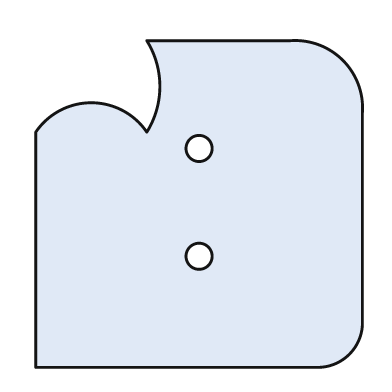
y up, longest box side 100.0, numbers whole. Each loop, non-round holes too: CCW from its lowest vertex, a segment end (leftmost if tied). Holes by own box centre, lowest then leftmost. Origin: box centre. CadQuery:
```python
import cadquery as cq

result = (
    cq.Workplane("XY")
    .moveTo(-50.0, -50.0)
    .lineTo(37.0, -50.0)
    .threePointArc((46.0, -46.0), (50.0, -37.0))
    .lineTo(50.0, 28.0)
    .threePointArc((44.0, 44.0), (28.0, 50.0))
    .lineTo(-16.0, 50.0)
    .threePointArc((-12.0, 36.0), (-16.0, 22.0))
    .threePointArc((-33.0, 31.0), (-50.0, 22.0))
    .close()
    .moveTo(0.0, -16.0)
    .circle(4.0)
    .moveTo(0.0, 17.0)
    .circle(4.0)
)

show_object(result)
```